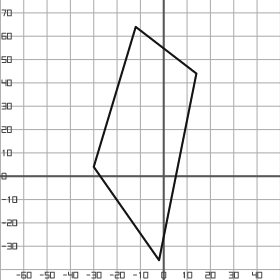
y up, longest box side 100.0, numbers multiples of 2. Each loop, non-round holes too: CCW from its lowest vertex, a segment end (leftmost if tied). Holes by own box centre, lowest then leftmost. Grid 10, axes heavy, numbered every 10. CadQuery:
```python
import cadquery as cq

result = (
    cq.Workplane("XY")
    .moveTo(-2.0, -36.0)
    .lineTo(14.0, 44.0)
    .lineTo(-12.0, 64.0)
    .lineTo(-30.0, 4.0)
    .close()
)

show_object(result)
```